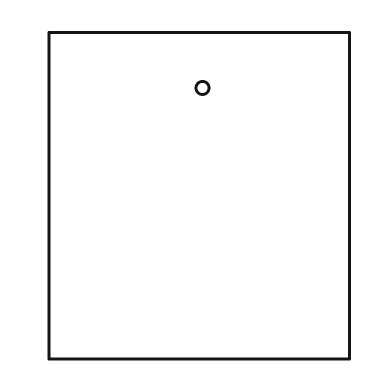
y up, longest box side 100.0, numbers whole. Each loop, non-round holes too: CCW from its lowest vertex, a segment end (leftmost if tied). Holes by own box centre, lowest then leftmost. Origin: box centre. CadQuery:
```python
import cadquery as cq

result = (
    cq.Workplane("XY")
    .moveTo(-46.0, -50.0)
    .lineTo(46.0, -50.0)
    .lineTo(46.0, 50.0)
    .lineTo(-46.0, 50.0)
    .close()
    .moveTo(1.0, 33.0)
    .circle(2.0)
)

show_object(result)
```